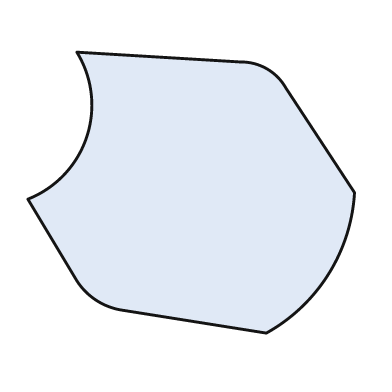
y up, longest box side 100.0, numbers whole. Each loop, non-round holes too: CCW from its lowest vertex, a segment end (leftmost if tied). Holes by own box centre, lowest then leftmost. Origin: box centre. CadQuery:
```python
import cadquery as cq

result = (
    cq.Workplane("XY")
    .moveTo(23.0, -43.0)
    .threePointArc((42.0, -25.0), (50.0, 0.0))
    .lineTo(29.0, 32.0)
    .threePointArc((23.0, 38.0), (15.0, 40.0))
    .lineTo(-35.0, 43.0)
    .threePointArc((-32.0, 17.0), (-50.0, -2.0))
    .lineTo(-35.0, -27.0)
    .threePointArc((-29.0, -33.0), (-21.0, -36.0))
    .close()
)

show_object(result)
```